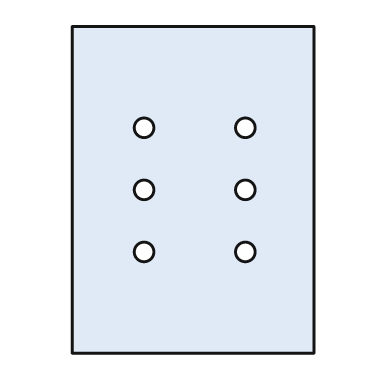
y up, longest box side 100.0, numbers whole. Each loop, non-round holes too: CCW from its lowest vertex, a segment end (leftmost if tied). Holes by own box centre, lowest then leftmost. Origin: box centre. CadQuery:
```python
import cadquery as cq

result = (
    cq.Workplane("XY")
    .moveTo(-37.0, -50.0)
    .lineTo(37.0, -50.0)
    .lineTo(37.0, 50.0)
    .lineTo(-37.0, 50.0)
    .close()
    .moveTo(-15.0, -19.0)
    .circle(3.0)
    .moveTo(16.0, -19.0)
    .circle(3.0)
    .moveTo(-15.0, 0.0)
    .circle(3.0)
    .moveTo(16.0, 0.0)
    .circle(3.0)
    .moveTo(-15.0, 19.0)
    .circle(3.0)
    .moveTo(16.0, 19.0)
    .circle(3.0)
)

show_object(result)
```